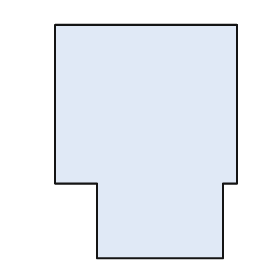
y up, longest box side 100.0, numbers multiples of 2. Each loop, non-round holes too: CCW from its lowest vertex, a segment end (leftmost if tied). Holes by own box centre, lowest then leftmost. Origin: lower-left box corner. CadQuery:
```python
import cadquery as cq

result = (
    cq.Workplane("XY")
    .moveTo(18.0, 0.0)
    .lineTo(72.0, 0.0)
    .lineTo(72.0, 32.0)
    .lineTo(78.0, 32.0)
    .lineTo(78.0, 100.0)
    .lineTo(0.0, 100.0)
    .lineTo(0.0, 32.0)
    .lineTo(18.0, 32.0)
    .close()
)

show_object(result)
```